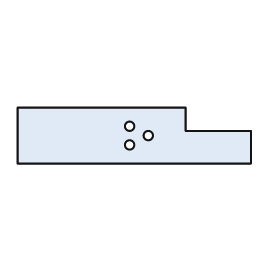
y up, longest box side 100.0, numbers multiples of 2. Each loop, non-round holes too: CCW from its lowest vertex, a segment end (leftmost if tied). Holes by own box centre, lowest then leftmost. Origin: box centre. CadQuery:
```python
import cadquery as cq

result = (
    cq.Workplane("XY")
    .moveTo(-50.0, -12.0)
    .lineTo(50.0, -12.0)
    .lineTo(50.0, 2.0)
    .lineTo(22.0, 2.0)
    .lineTo(22.0, 12.0)
    .lineTo(-50.0, 12.0)
    .close()
    .moveTo(-2.0, -4.0)
    .circle(2.0)
    .moveTo(6.0, 0.0)
    .circle(2.0)
    .moveTo(-2.0, 4.0)
    .circle(2.0)
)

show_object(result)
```